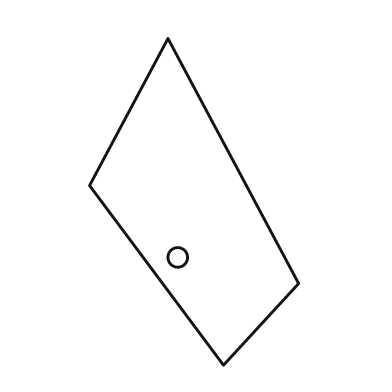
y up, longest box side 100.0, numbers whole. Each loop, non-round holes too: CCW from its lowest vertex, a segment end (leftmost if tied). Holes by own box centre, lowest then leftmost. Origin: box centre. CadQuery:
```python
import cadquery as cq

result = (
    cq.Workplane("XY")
    .moveTo(9.0, -50.0)
    .lineTo(32.0, -25.0)
    .lineTo(-8.0, 50.0)
    .lineTo(-32.0, 5.0)
    .close()
    .moveTo(-5.0, -17.0)
    .circle(3.0)
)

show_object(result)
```